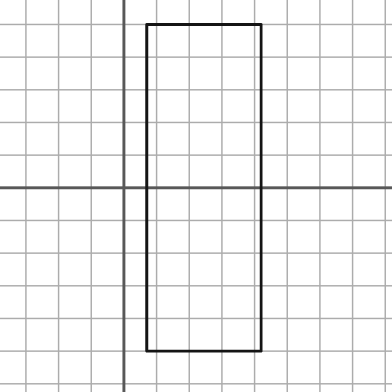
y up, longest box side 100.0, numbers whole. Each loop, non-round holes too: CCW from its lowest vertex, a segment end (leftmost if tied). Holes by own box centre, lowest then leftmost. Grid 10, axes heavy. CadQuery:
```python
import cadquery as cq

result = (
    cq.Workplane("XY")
    .moveTo(7.0, -50.0)
    .lineTo(42.0, -50.0)
    .lineTo(42.0, 50.0)
    .lineTo(7.0, 50.0)
    .close()
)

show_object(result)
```